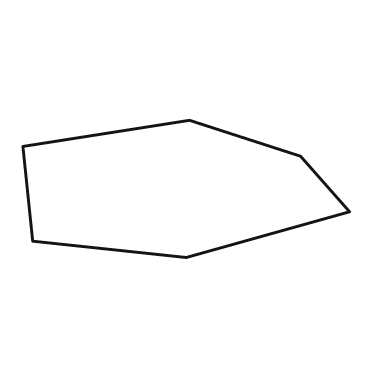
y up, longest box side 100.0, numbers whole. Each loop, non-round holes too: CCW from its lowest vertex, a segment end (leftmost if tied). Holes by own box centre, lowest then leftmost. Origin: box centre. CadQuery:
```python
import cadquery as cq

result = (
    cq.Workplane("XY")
    .moveTo(0.0, -21.0)
    .lineTo(50.0, -7.0)
    .lineTo(35.0, 10.0)
    .lineTo(1.0, 21.0)
    .lineTo(-50.0, 13.0)
    .lineTo(-47.0, -16.0)
    .close()
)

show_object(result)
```